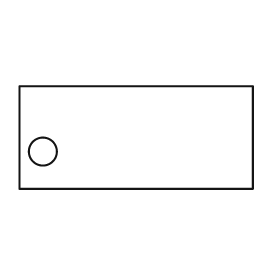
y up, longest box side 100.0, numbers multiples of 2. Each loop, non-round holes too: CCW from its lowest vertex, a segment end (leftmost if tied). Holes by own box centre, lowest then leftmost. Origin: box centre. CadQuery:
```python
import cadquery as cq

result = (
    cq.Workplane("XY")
    .moveTo(-50.0, -22.0)
    .lineTo(50.0, -22.0)
    .lineTo(50.0, 22.0)
    .lineTo(-50.0, 22.0)
    .close()
    .moveTo(-40.0, -6.0)
    .circle(6.0)
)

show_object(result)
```